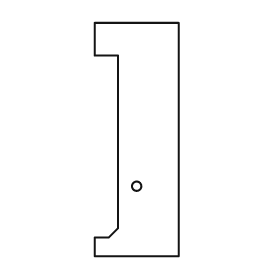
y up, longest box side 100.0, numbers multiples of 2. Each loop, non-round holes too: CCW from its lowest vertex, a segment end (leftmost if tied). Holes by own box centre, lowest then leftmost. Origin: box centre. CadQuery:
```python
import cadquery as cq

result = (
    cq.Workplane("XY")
    .moveTo(-18.0, -50.0)
    .lineTo(18.0, -50.0)
    .lineTo(18.0, 50.0)
    .lineTo(-18.0, 50.0)
    .lineTo(-18.0, 36.0)
    .lineTo(-8.0, 36.0)
    .lineTo(-8.0, -38.0)
    .lineTo(-12.0, -42.0)
    .lineTo(-18.0, -42.0)
    .close()
    .moveTo(0.0, -20.0)
    .circle(2.0)
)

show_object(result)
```